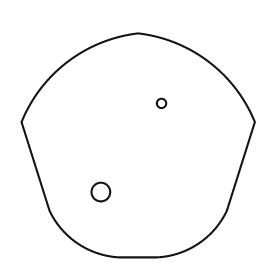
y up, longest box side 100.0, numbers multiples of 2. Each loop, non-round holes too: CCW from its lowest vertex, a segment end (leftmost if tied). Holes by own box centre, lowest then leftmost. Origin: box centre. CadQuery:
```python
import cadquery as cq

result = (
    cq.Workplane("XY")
    .moveTo(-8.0, -48.0)
    .lineTo(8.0, -48.0)
    .threePointArc((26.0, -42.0), (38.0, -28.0))
    .lineTo(50.0, 10.0)
    .threePointArc((30.0, 36.0), (0.0, 48.0))
    .threePointArc((-30.0, 36.0), (-50.0, 10.0))
    .lineTo(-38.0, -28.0)
    .threePointArc((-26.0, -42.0), (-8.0, -48.0))
    .close()
    .moveTo(-16.0, -20.0)
    .circle(4.0)
    .moveTo(10.0, 18.0)
    .circle(2.0)
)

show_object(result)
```